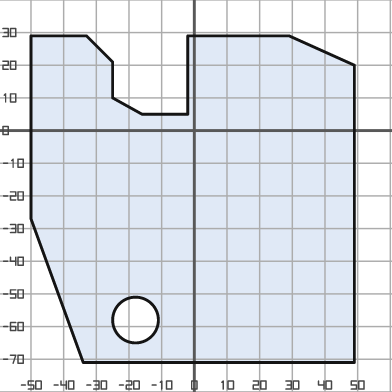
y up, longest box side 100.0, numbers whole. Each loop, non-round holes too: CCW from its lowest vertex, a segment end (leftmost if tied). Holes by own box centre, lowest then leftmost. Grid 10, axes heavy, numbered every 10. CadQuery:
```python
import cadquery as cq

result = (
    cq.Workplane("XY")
    .moveTo(-34.0, -71.0)
    .lineTo(49.0, -71.0)
    .lineTo(49.0, 20.0)
    .lineTo(29.0, 29.0)
    .lineTo(-2.0, 29.0)
    .lineTo(-2.0, 5.0)
    .lineTo(-16.0, 5.0)
    .lineTo(-25.0, 10.0)
    .lineTo(-25.0, 21.0)
    .lineTo(-33.0, 29.0)
    .lineTo(-50.0, 29.0)
    .lineTo(-50.0, -27.0)
    .close()
    .moveTo(-18.0, -58.0)
    .circle(7.0)
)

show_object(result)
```